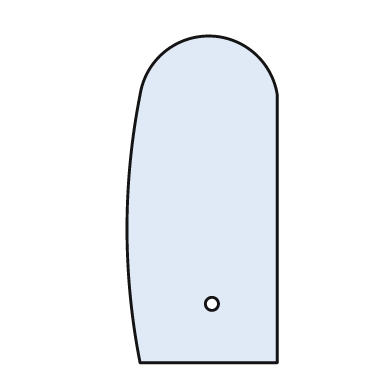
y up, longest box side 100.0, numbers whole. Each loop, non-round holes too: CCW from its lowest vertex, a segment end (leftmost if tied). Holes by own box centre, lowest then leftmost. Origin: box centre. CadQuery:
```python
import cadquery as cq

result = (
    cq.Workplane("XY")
    .moveTo(-19.0, -50.0)
    .lineTo(23.0, -50.0)
    .lineTo(23.0, 32.0)
    .threePointArc((2.0, 50.0), (-19.0, 32.0))
    .threePointArc((-23.0, -9.0), (-19.0, -50.0))
    .close()
    .moveTo(3.0, -32.0)
    .circle(2.0)
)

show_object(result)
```